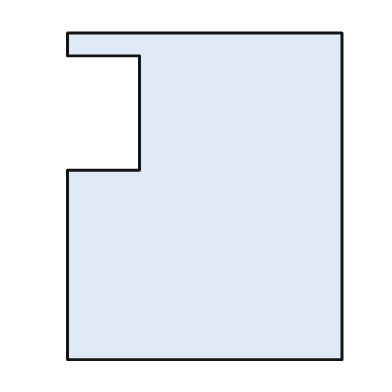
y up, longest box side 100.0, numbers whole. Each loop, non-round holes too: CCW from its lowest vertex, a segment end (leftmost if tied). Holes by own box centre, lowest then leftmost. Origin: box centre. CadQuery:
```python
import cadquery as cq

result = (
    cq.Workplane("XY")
    .moveTo(-42.0, -50.0)
    .lineTo(42.0, -50.0)
    .lineTo(42.0, 50.0)
    .lineTo(-42.0, 50.0)
    .lineTo(-42.0, 43.0)
    .lineTo(-20.0, 43.0)
    .lineTo(-20.0, 8.0)
    .lineTo(-42.0, 8.0)
    .close()
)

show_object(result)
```